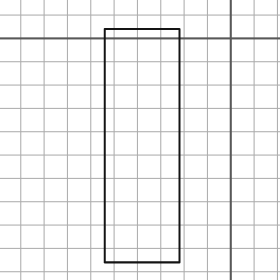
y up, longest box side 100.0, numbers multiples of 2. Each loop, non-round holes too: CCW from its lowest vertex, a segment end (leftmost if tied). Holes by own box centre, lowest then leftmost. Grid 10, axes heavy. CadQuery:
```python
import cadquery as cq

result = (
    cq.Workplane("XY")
    .moveTo(-54.0, -96.0)
    .lineTo(-22.0, -96.0)
    .lineTo(-22.0, 4.0)
    .lineTo(-54.0, 4.0)
    .close()
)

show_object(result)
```